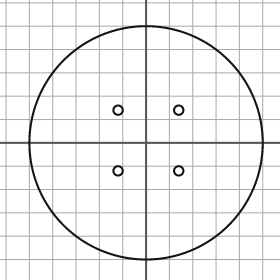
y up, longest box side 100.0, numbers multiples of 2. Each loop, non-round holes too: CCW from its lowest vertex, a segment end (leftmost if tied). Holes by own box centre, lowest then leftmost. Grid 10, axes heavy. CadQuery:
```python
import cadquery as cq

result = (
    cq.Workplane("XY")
    .moveTo(0.0, 0.0)
    .circle(50.0)
    .moveTo(-12.0, -12.0)
    .circle(2.0)
    .moveTo(14.0, -12.0)
    .circle(2.0)
    .moveTo(-12.0, 14.0)
    .circle(2.0)
    .moveTo(14.0, 14.0)
    .circle(2.0)
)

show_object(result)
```